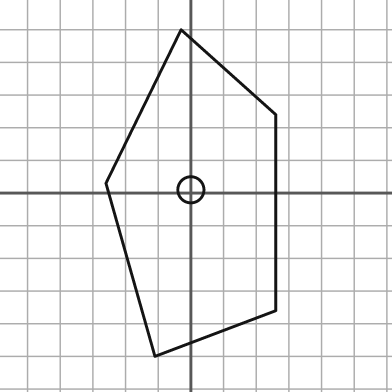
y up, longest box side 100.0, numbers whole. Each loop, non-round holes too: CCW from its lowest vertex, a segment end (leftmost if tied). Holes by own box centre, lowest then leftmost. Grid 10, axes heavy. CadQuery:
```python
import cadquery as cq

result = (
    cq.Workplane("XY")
    .moveTo(-11.0, -50.0)
    .lineTo(26.0, -36.0)
    .lineTo(26.0, 24.0)
    .lineTo(-3.0, 50.0)
    .lineTo(-26.0, 3.0)
    .close()
    .moveTo(0.0, 1.0)
    .circle(4.0)
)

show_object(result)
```